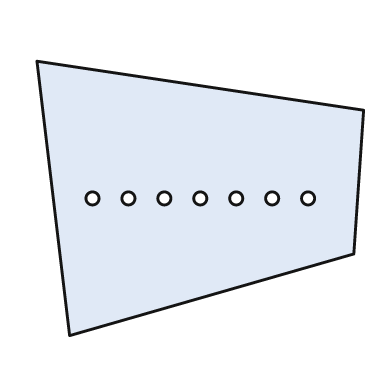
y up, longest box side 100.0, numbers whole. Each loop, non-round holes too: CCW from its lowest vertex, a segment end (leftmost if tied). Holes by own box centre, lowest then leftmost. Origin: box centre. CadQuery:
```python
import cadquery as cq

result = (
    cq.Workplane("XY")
    .moveTo(-40.0, -42.0)
    .lineTo(47.0, -17.0)
    .lineTo(50.0, 27.0)
    .lineTo(-50.0, 42.0)
    .close()
    .moveTo(-33.0, 0.0)
    .circle(2.0)
    .moveTo(-22.0, 0.0)
    .circle(2.0)
    .moveTo(-11.0, 0.0)
    .circle(2.0)
    .moveTo(0.0, 0.0)
    .circle(2.0)
    .moveTo(11.0, 0.0)
    .circle(2.0)
    .moveTo(22.0, 0.0)
    .circle(2.0)
    .moveTo(33.0, 0.0)
    .circle(2.0)
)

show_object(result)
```